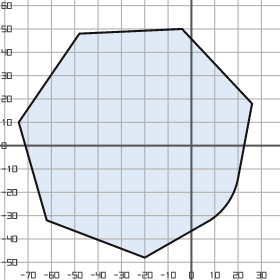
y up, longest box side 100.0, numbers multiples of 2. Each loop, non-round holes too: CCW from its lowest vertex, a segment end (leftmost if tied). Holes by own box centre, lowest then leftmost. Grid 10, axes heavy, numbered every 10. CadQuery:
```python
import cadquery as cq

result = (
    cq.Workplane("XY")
    .moveTo(-20.0, -48.0)
    .lineTo(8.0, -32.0)
    .threePointArc((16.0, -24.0), (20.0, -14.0))
    .lineTo(26.0, 18.0)
    .lineTo(-4.0, 50.0)
    .lineTo(-48.0, 48.0)
    .lineTo(-74.0, 10.0)
    .lineTo(-62.0, -32.0)
    .close()
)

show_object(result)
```